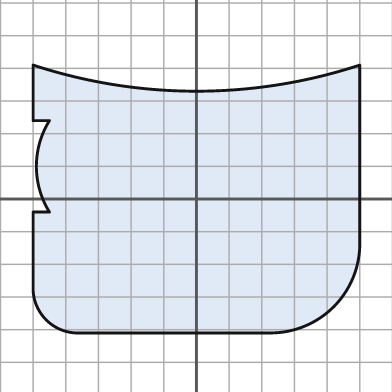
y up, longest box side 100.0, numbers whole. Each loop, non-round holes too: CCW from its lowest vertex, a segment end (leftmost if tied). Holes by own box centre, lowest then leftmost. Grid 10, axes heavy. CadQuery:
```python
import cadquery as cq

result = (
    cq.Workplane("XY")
    .moveTo(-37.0, -41.0)
    .lineTo(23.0, -41.0)
    .threePointArc((42.0, -33.0), (50.0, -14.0))
    .lineTo(50.0, 41.0)
    .threePointArc((0.0, 33.0), (-50.0, 41.0))
    .lineTo(-50.0, 24.0)
    .lineTo(-45.0, 24.0)
    .threePointArc((-49.0, 10.0), (-45.0, -4.0))
    .lineTo(-50.0, -4.0)
    .lineTo(-50.0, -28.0)
    .threePointArc((-46.0, -37.0), (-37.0, -41.0))
    .close()
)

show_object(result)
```